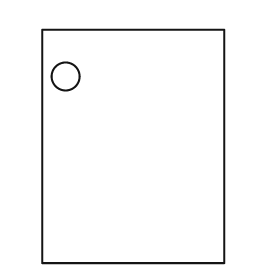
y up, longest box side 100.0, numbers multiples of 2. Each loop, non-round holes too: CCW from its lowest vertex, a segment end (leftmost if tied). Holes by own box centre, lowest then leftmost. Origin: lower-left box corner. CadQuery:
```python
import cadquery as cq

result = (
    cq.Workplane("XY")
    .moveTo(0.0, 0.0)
    .lineTo(78.0, 0.0)
    .lineTo(78.0, 100.0)
    .lineTo(0.0, 100.0)
    .close()
    .moveTo(10.0, 80.0)
    .circle(6.0)
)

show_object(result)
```